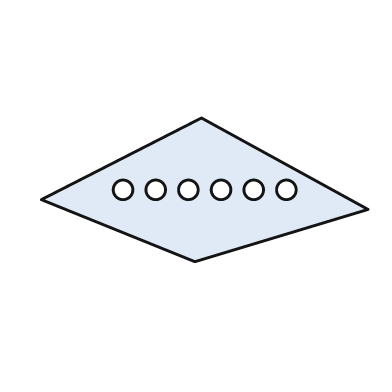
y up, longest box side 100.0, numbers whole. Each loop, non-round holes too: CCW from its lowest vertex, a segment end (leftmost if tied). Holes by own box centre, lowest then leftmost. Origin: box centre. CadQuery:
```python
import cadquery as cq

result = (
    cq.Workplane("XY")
    .moveTo(-3.0, -22.0)
    .lineTo(50.0, -6.0)
    .lineTo(-1.0, 22.0)
    .lineTo(-50.0, -3.0)
    .close()
    .moveTo(-25.0, 0.0)
    .circle(3.0)
    .moveTo(-15.0, 0.0)
    .circle(3.0)
    .moveTo(-5.0, 0.0)
    .circle(3.0)
    .moveTo(5.0, 0.0)
    .circle(3.0)
    .moveTo(15.0, 0.0)
    .circle(3.0)
    .moveTo(25.0, 0.0)
    .circle(3.0)
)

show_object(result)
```